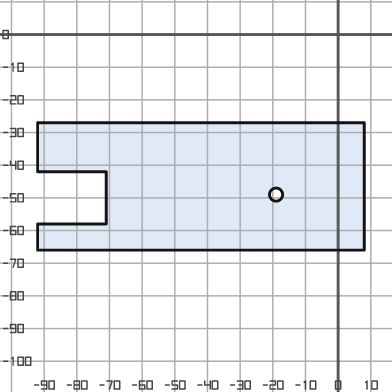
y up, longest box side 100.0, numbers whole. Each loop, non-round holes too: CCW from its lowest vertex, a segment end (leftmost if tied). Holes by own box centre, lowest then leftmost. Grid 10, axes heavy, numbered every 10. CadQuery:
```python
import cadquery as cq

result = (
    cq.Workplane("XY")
    .moveTo(-92.0, -66.0)
    .lineTo(8.0, -66.0)
    .lineTo(8.0, -27.0)
    .lineTo(-92.0, -27.0)
    .lineTo(-92.0, -42.0)
    .lineTo(-71.0, -42.0)
    .lineTo(-71.0, -58.0)
    .lineTo(-92.0, -58.0)
    .close()
    .moveTo(-19.0, -49.0)
    .circle(2.0)
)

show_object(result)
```